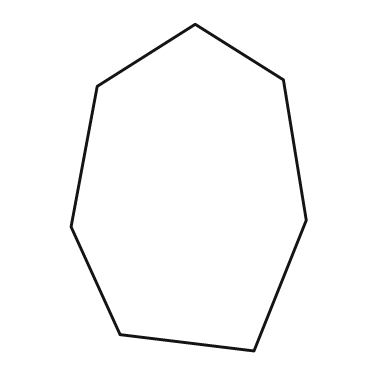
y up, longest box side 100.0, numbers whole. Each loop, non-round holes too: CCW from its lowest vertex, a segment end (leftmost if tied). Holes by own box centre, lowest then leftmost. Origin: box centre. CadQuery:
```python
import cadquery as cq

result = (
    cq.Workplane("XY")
    .moveTo(20.0, -50.0)
    .lineTo(36.0, -10.0)
    .lineTo(29.0, 33.0)
    .lineTo(2.0, 50.0)
    .lineTo(-28.0, 31.0)
    .lineTo(-36.0, -12.0)
    .lineTo(-21.0, -45.0)
    .close()
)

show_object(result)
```